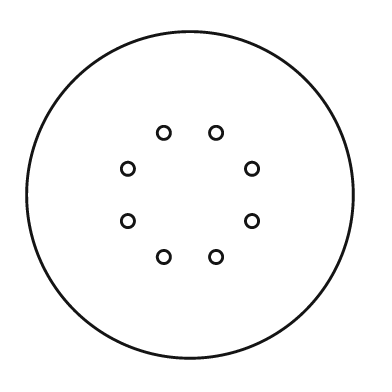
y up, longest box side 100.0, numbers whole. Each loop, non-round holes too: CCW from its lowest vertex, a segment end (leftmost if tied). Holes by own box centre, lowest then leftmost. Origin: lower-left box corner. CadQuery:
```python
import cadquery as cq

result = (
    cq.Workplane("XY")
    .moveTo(50.0, 50.0)
    .circle(50.0)
    .moveTo(42.0, 31.0)
    .circle(2.0)
    .moveTo(58.0, 31.0)
    .circle(2.0)
    .moveTo(31.0, 42.0)
    .circle(2.0)
    .moveTo(69.0, 42.0)
    .circle(2.0)
    .moveTo(31.0, 58.0)
    .circle(2.0)
    .moveTo(69.0, 58.0)
    .circle(2.0)
    .moveTo(42.0, 69.0)
    .circle(2.0)
    .moveTo(58.0, 69.0)
    .circle(2.0)
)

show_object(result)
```